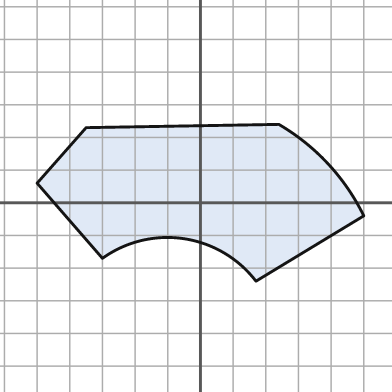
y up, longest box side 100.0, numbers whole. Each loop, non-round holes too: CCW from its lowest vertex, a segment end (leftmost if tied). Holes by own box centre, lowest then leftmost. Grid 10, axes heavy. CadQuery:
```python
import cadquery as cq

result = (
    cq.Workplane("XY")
    .moveTo(17.0, -24.0)
    .lineTo(50.0, -4.0)
    .threePointArc((39.0, 12.0), (24.0, 24.0))
    .lineTo(-35.0, 23.0)
    .lineTo(-50.0, 6.0)
    .lineTo(-30.0, -17.0)
    .threePointArc((-5.0, -11.0), (17.0, -24.0))
    .close()
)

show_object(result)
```